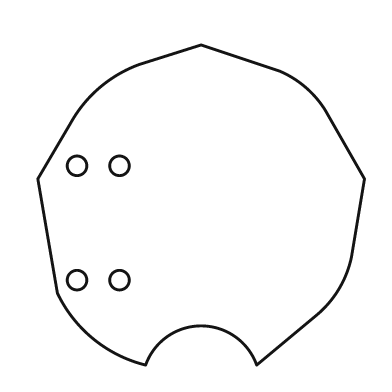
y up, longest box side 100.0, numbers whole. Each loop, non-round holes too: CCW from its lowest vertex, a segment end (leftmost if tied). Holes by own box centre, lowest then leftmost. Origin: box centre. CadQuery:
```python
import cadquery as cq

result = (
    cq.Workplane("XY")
    .moveTo(-17.0, -49.0)
    .threePointArc((0.0, -37.0), (17.0, -49.0))
    .lineTo(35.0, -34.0)
    .threePointArc((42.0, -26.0), (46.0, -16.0))
    .lineTo(50.0, 8.0)
    .lineTo(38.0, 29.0)
    .threePointArc((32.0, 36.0), (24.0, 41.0))
    .lineTo(0.0, 49.0)
    .lineTo(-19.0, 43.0)
    .threePointArc((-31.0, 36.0), (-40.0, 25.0))
    .lineTo(-50.0, 8.0)
    .lineTo(-44.0, -27.0)
    .threePointArc((-33.0, -41.0), (-17.0, -49.0))
    .close()
    .moveTo(-38.0, -23.0)
    .circle(3.0)
    .moveTo(-25.0, -23.0)
    .circle(3.0)
    .moveTo(-38.0, 12.0)
    .circle(3.0)
    .moveTo(-25.0, 12.0)
    .circle(3.0)
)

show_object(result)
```